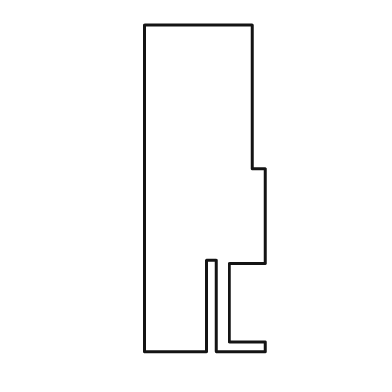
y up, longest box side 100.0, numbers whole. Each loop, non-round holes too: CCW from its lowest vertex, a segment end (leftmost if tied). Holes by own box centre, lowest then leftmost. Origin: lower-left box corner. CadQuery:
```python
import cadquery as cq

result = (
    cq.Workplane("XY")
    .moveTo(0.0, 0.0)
    .lineTo(19.0, 0.0)
    .lineTo(19.0, 28.0)
    .lineTo(22.0, 28.0)
    .lineTo(22.0, 0.0)
    .lineTo(37.0, 0.0)
    .lineTo(37.0, 3.0)
    .lineTo(26.0, 3.0)
    .lineTo(26.0, 27.0)
    .lineTo(37.0, 27.0)
    .lineTo(37.0, 56.0)
    .lineTo(33.0, 56.0)
    .lineTo(33.0, 100.0)
    .lineTo(0.0, 100.0)
    .close()
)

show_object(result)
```